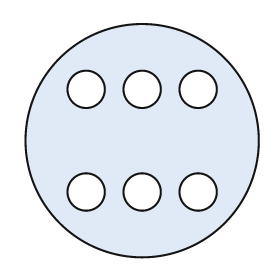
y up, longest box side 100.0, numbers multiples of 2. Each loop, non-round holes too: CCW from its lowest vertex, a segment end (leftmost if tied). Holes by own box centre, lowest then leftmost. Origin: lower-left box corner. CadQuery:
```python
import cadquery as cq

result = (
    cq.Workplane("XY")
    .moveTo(50.0, 50.0)
    .circle(50.0)
    .moveTo(26.0, 28.0)
    .circle(8.0)
    .moveTo(50.0, 28.0)
    .circle(8.0)
    .moveTo(74.0, 28.0)
    .circle(8.0)
    .moveTo(26.0, 72.0)
    .circle(8.0)
    .moveTo(50.0, 72.0)
    .circle(8.0)
    .moveTo(74.0, 72.0)
    .circle(8.0)
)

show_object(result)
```